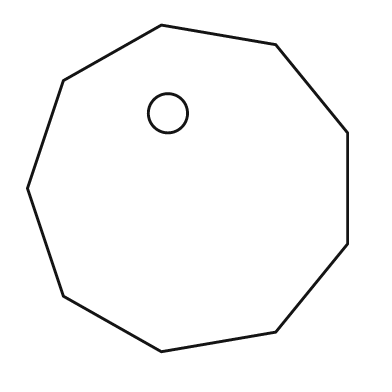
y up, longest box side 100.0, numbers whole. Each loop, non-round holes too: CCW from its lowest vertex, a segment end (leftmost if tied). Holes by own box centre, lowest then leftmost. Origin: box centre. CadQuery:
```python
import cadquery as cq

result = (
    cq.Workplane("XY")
    .moveTo(-8.0, -50.0)
    .lineTo(27.0, -44.0)
    .lineTo(49.0, -17.0)
    .lineTo(49.0, 17.0)
    .lineTo(27.0, 44.0)
    .lineTo(-8.0, 50.0)
    .lineTo(-38.0, 33.0)
    .lineTo(-49.0, 0.0)
    .lineTo(-38.0, -33.0)
    .close()
    .moveTo(-6.0, 23.0)
    .circle(6.0)
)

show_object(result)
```